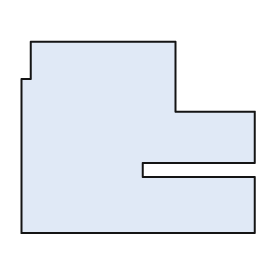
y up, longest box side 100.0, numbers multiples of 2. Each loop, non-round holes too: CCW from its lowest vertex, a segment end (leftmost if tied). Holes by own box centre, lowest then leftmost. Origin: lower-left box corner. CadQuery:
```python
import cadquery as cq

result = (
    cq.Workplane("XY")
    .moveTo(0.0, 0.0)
    .lineTo(100.0, 0.0)
    .lineTo(100.0, 24.0)
    .lineTo(52.0, 24.0)
    .lineTo(52.0, 30.0)
    .lineTo(100.0, 30.0)
    .lineTo(100.0, 52.0)
    .lineTo(66.0, 52.0)
    .lineTo(66.0, 82.0)
    .lineTo(4.0, 82.0)
    .lineTo(4.0, 66.0)
    .lineTo(0.0, 66.0)
    .close()
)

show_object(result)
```